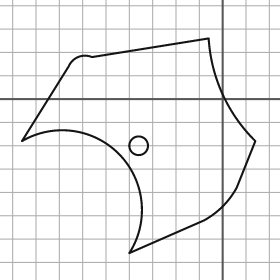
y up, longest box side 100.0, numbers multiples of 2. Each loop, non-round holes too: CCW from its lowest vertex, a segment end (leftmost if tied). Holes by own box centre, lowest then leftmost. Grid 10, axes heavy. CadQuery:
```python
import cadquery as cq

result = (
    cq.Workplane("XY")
    .moveTo(-40.0, -66.0)
    .lineTo(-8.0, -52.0)
    .threePointArc((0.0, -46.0), (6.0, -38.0))
    .lineTo(14.0, -18.0)
    .threePointArc((0.0, 2.0), (-6.0, 26.0))
    .lineTo(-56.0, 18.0)
    .threePointArc((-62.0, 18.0), (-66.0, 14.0))
    .lineTo(-86.0, -18.0)
    .threePointArc((-44.0, -24.0), (-40.0, -66.0))
    .close()
    .moveTo(-36.0, -20.0)
    .circle(4.0)
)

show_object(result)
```